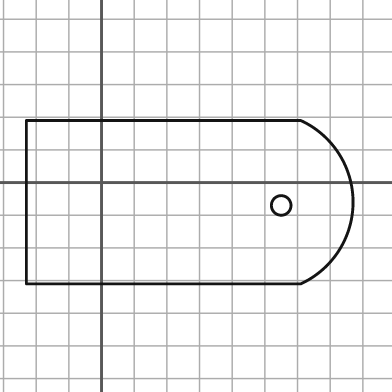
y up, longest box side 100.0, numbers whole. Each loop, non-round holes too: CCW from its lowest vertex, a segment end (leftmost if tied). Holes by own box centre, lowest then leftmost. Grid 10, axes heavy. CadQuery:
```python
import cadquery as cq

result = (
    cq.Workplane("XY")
    .moveTo(-23.0, -31.0)
    .lineTo(61.0, -31.0)
    .threePointArc((77.0, -6.0), (61.0, 19.0))
    .lineTo(-23.0, 19.0)
    .close()
    .moveTo(55.0, -7.0)
    .circle(3.0)
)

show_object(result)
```